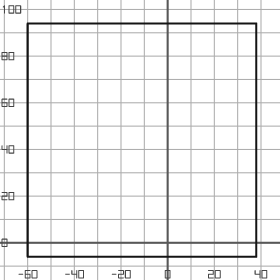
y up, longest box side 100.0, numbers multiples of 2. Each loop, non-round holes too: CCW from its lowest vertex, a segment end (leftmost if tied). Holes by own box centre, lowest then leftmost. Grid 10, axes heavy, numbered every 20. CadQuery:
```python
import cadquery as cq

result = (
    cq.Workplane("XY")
    .moveTo(-60.0, -6.0)
    .lineTo(38.0, -6.0)
    .lineTo(38.0, 94.0)
    .lineTo(-60.0, 94.0)
    .close()
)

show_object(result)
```